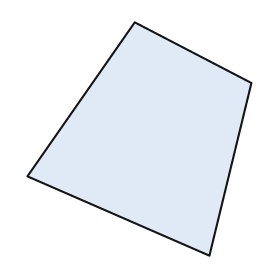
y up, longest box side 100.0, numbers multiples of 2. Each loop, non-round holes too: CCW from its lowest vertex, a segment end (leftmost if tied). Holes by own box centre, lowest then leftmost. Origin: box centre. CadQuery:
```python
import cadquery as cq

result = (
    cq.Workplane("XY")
    .moveTo(30.0, -50.0)
    .lineTo(48.0, 24.0)
    .lineTo(-2.0, 50.0)
    .lineTo(-48.0, -16.0)
    .close()
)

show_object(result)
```